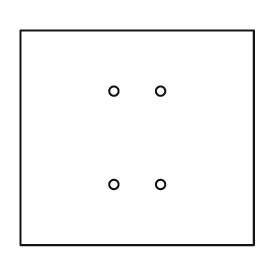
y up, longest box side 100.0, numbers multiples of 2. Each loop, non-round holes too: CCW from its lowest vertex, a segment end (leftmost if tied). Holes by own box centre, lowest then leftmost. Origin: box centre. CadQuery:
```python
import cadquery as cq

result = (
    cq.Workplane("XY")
    .moveTo(-50.0, -46.0)
    .lineTo(50.0, -46.0)
    .lineTo(50.0, 46.0)
    .lineTo(-50.0, 46.0)
    .close()
    .moveTo(-10.0, -20.0)
    .circle(2.0)
    .moveTo(10.0, -20.0)
    .circle(2.0)
    .moveTo(-10.0, 20.0)
    .circle(2.0)
    .moveTo(10.0, 20.0)
    .circle(2.0)
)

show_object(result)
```